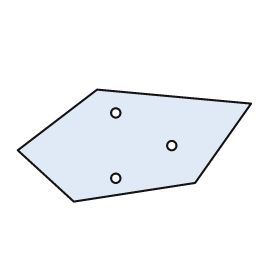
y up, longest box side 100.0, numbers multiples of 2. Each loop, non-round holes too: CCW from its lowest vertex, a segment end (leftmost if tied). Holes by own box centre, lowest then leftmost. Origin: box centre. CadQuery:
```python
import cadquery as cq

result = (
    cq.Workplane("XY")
    .moveTo(-26.0, -24.0)
    .lineTo(26.0, -16.0)
    .lineTo(50.0, 18.0)
    .lineTo(-16.0, 24.0)
    .lineTo(-50.0, -2.0)
    .close()
    .moveTo(-8.0, -14.0)
    .circle(2.0)
    .moveTo(16.0, 0.0)
    .circle(2.0)
    .moveTo(-8.0, 14.0)
    .circle(2.0)
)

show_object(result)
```